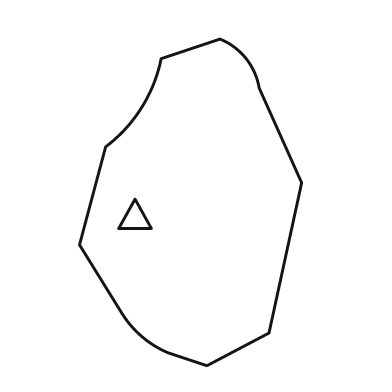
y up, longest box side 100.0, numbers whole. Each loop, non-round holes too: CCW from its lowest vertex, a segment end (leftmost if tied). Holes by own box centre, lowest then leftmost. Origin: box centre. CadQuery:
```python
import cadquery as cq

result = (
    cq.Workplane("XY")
    .moveTo(5.0, -50.0)
    .lineTo(24.0, -40.0)
    .lineTo(34.0, 6.0)
    .lineTo(21.0, 35.0)
    .threePointArc((17.0, 44.0), (9.0, 50.0))
    .lineTo(-9.0, 44.0)
    .threePointArc((-15.0, 29.0), (-26.0, 17.0))
    .lineTo(-34.0, -13.0)
    .lineTo(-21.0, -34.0)
    .threePointArc((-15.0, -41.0), (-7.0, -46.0))
    .close()
    .moveTo(-22.0, -8.0)
    .lineTo(-12.0, -8.0)
    .lineTo(-17.0, 1.0)
    .close()
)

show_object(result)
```